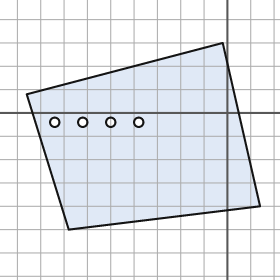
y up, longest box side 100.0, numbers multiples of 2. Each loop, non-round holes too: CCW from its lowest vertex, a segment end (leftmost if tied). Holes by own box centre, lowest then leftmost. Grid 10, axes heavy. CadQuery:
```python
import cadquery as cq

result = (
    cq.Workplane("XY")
    .moveTo(-68.0, -50.0)
    .lineTo(14.0, -40.0)
    .lineTo(-2.0, 30.0)
    .lineTo(-86.0, 8.0)
    .close()
    .moveTo(-74.0, -4.0)
    .circle(2.0)
    .moveTo(-62.0, -4.0)
    .circle(2.0)
    .moveTo(-50.0, -4.0)
    .circle(2.0)
    .moveTo(-38.0, -4.0)
    .circle(2.0)
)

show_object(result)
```